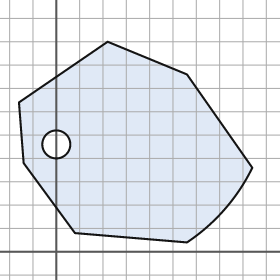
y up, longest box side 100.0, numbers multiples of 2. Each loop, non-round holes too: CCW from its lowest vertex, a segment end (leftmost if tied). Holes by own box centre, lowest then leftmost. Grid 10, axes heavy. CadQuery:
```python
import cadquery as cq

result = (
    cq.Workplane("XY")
    .moveTo(56.0, 4.0)
    .threePointArc((72.0, 18.0), (84.0, 36.0))
    .lineTo(56.0, 76.0)
    .lineTo(22.0, 90.0)
    .lineTo(-16.0, 64.0)
    .lineTo(-14.0, 38.0)
    .lineTo(8.0, 8.0)
    .close()
    .moveTo(0.0, 46.0)
    .circle(6.0)
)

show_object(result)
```